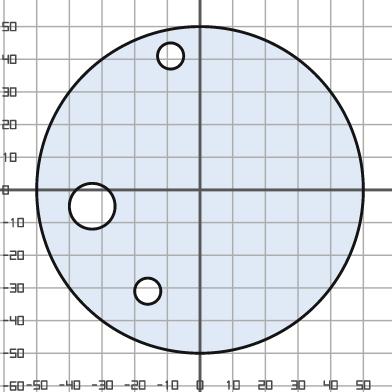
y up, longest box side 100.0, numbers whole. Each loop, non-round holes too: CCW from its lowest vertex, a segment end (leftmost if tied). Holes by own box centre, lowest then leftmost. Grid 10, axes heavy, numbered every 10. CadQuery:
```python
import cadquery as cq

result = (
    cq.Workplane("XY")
    .moveTo(0.0, 0.0)
    .circle(50.0)
    .moveTo(-16.0, -31.0)
    .circle(4.0)
    .moveTo(-33.0, -5.0)
    .circle(7.0)
    .moveTo(-9.0, 41.0)
    .circle(4.0)
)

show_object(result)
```